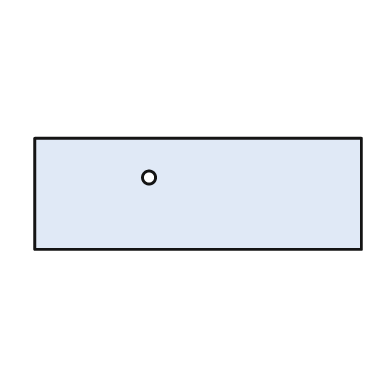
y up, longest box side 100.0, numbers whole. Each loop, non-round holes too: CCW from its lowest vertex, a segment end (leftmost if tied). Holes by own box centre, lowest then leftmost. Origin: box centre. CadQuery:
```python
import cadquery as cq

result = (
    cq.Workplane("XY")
    .moveTo(-50.0, -17.0)
    .lineTo(50.0, -17.0)
    .lineTo(50.0, 17.0)
    .lineTo(-50.0, 17.0)
    .close()
    .moveTo(-15.0, 5.0)
    .circle(2.0)
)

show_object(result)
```